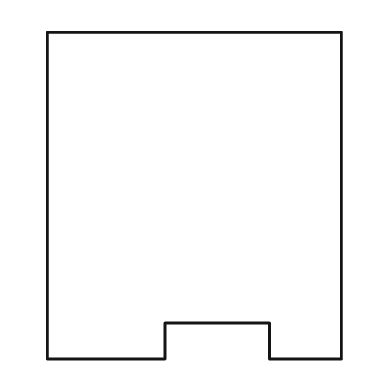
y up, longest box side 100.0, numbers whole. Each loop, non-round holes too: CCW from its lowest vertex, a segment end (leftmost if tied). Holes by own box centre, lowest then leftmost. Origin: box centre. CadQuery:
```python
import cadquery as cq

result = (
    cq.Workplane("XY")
    .moveTo(-45.0, -50.0)
    .lineTo(-9.0, -50.0)
    .lineTo(-9.0, -39.0)
    .lineTo(23.0, -39.0)
    .lineTo(23.0, -50.0)
    .lineTo(45.0, -50.0)
    .lineTo(45.0, 50.0)
    .lineTo(-45.0, 50.0)
    .close()
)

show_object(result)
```